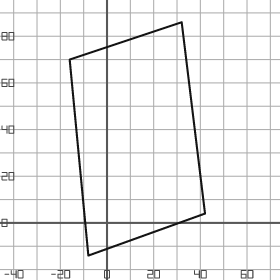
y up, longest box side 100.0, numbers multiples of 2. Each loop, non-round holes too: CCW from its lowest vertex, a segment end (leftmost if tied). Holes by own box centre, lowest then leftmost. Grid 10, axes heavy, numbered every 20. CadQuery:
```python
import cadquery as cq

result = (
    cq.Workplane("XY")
    .moveTo(-8.0, -14.0)
    .lineTo(42.0, 4.0)
    .lineTo(32.0, 86.0)
    .lineTo(-16.0, 70.0)
    .close()
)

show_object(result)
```